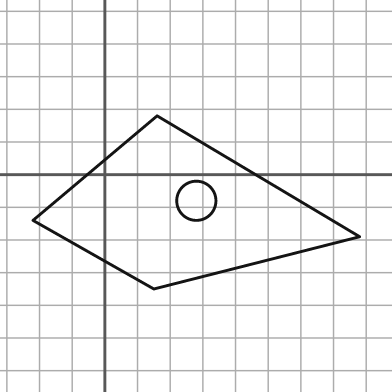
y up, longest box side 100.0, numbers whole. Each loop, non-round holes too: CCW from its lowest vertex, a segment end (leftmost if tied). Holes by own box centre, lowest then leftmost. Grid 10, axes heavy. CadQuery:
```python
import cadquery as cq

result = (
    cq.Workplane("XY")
    .moveTo(15.0, -35.0)
    .lineTo(78.0, -19.0)
    .lineTo(16.0, 18.0)
    .lineTo(-22.0, -14.0)
    .close()
    .moveTo(28.0, -8.0)
    .circle(6.0)
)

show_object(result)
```